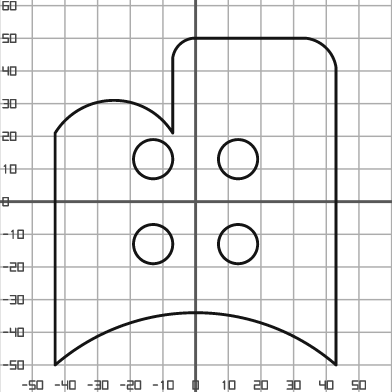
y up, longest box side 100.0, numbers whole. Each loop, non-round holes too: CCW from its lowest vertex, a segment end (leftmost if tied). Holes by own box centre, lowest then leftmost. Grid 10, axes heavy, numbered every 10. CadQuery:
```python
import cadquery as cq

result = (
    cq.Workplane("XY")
    .moveTo(-43.0, -50.0)
    .threePointArc((0.0, -34.0), (43.0, -50.0))
    .lineTo(43.0, 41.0)
    .threePointArc((40.0, 47.0), (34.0, 50.0))
    .lineTo(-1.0, 50.0)
    .threePointArc((-5.0, 48.0), (-7.0, 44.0))
    .lineTo(-7.0, 21.0)
    .threePointArc((-25.0, 31.0), (-43.0, 21.0))
    .close()
    .moveTo(-13.0, -13.0)
    .circle(6.0)
    .moveTo(13.0, -13.0)
    .circle(6.0)
    .moveTo(-13.0, 13.0)
    .circle(6.0)
    .moveTo(13.0, 13.0)
    .circle(6.0)
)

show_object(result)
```